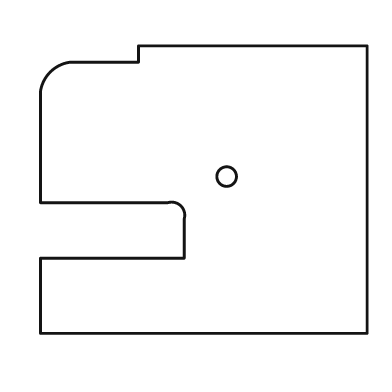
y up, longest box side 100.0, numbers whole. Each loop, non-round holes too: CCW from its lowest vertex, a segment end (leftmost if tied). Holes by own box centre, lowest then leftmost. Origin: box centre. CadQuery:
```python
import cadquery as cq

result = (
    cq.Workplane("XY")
    .moveTo(-50.0, -44.0)
    .lineTo(50.0, -44.0)
    .lineTo(50.0, 44.0)
    .lineTo(-20.0, 44.0)
    .lineTo(-20.0, 39.0)
    .lineTo(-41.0, 39.0)
    .threePointArc((-47.0, 36.0), (-50.0, 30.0))
    .lineTo(-50.0, -4.0)
    .lineTo(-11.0, -4.0)
    .threePointArc((-7.0, -5.0), (-6.0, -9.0))
    .lineTo(-6.0, -21.0)
    .lineTo(-50.0, -21.0)
    .close()
    .moveTo(7.0, 4.0)
    .circle(3.0)
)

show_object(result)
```